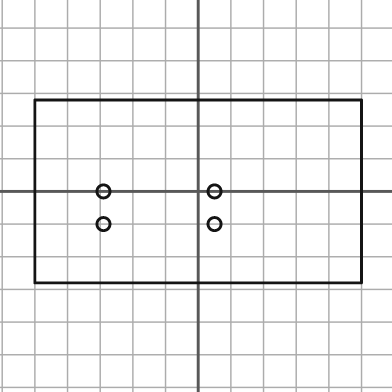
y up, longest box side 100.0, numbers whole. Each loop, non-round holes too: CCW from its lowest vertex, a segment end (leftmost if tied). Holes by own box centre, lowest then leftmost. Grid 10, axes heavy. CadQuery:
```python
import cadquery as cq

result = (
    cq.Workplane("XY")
    .moveTo(-50.0, -28.0)
    .lineTo(50.0, -28.0)
    .lineTo(50.0, 28.0)
    .lineTo(-50.0, 28.0)
    .close()
    .moveTo(-29.0, -10.0)
    .circle(2.0)
    .moveTo(5.0, -10.0)
    .circle(2.0)
    .moveTo(-29.0, 0.0)
    .circle(2.0)
    .moveTo(5.0, 0.0)
    .circle(2.0)
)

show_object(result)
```